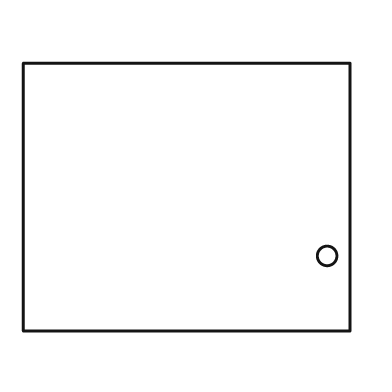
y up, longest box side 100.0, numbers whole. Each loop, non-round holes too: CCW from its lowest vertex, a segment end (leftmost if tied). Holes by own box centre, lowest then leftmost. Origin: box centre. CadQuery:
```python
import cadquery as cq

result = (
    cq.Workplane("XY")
    .moveTo(-50.0, -41.0)
    .lineTo(50.0, -41.0)
    .lineTo(50.0, 41.0)
    .lineTo(-50.0, 41.0)
    .close()
    .moveTo(43.0, -18.0)
    .circle(3.0)
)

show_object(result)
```